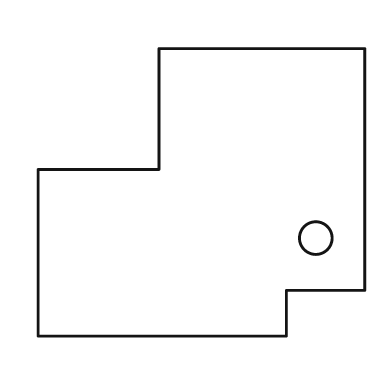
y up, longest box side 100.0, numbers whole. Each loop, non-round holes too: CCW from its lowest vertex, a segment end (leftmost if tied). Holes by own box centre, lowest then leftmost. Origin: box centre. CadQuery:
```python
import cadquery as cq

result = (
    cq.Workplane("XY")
    .moveTo(-50.0, -44.0)
    .lineTo(26.0, -44.0)
    .lineTo(26.0, -30.0)
    .lineTo(50.0, -30.0)
    .lineTo(50.0, 44.0)
    .lineTo(-13.0, 44.0)
    .lineTo(-13.0, 7.0)
    .lineTo(-50.0, 7.0)
    .close()
    .moveTo(35.0, -14.0)
    .circle(5.0)
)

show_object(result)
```